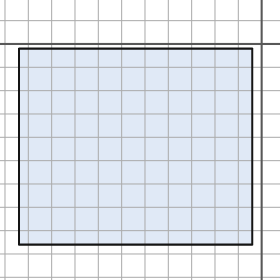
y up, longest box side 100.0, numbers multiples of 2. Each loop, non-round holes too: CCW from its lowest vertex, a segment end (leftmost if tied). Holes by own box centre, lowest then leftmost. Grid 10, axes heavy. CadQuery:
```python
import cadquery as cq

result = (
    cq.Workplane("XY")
    .moveTo(-104.0, -86.0)
    .lineTo(-4.0, -86.0)
    .lineTo(-4.0, -2.0)
    .lineTo(-104.0, -2.0)
    .close()
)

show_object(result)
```